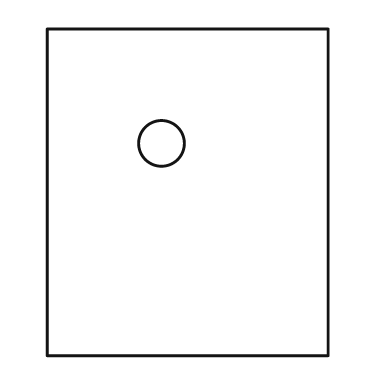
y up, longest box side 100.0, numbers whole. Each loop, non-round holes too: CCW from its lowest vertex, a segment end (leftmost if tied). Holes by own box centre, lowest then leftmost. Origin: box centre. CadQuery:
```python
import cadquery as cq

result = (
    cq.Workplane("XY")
    .moveTo(-43.0, -50.0)
    .lineTo(43.0, -50.0)
    .lineTo(43.0, 50.0)
    .lineTo(-43.0, 50.0)
    .close()
    .moveTo(-8.0, 15.0)
    .circle(7.0)
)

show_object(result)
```